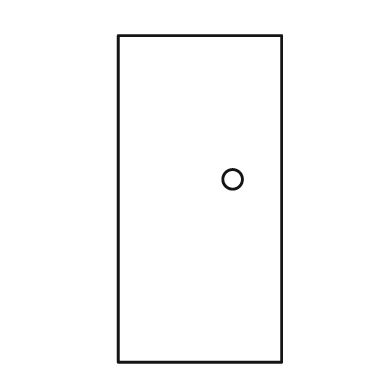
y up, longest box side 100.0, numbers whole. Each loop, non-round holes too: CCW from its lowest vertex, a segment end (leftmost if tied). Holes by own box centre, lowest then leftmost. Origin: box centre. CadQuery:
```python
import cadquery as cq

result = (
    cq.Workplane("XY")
    .moveTo(-25.0, -50.0)
    .lineTo(25.0, -50.0)
    .lineTo(25.0, 50.0)
    .lineTo(-25.0, 50.0)
    .close()
    .moveTo(10.0, 6.0)
    .circle(3.0)
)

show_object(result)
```